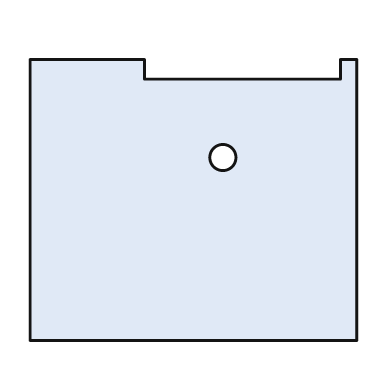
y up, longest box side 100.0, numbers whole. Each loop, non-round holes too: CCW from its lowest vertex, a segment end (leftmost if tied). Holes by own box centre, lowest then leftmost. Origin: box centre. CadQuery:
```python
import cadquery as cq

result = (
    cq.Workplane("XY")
    .moveTo(-50.0, -43.0)
    .lineTo(50.0, -43.0)
    .lineTo(50.0, 43.0)
    .lineTo(45.0, 43.0)
    .lineTo(45.0, 37.0)
    .lineTo(-15.0, 37.0)
    .lineTo(-15.0, 43.0)
    .lineTo(-50.0, 43.0)
    .close()
    .moveTo(9.0, 13.0)
    .circle(4.0)
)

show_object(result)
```